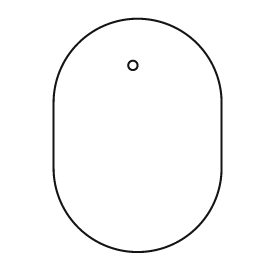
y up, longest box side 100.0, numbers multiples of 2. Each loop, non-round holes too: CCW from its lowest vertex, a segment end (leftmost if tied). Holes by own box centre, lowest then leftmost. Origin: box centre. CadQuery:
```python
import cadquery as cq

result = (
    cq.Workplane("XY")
    .moveTo(-36.0, -14.0)
    .threePointArc((0.0, -50.0), (36.0, -14.0))
    .lineTo(36.0, 14.0)
    .threePointArc((0.0, 50.0), (-36.0, 14.0))
    .close()
    .moveTo(-2.0, 30.0)
    .circle(2.0)
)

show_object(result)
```